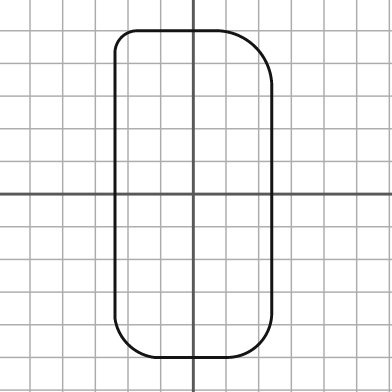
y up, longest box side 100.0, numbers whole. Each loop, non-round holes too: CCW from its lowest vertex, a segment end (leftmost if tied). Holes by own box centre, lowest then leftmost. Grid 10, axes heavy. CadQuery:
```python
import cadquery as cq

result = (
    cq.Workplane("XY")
    .moveTo(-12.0, -50.0)
    .lineTo(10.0, -50.0)
    .threePointArc((20.0, -46.0), (24.0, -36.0))
    .lineTo(24.0, 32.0)
    .threePointArc((19.0, 45.0), (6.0, 50.0))
    .lineTo(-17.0, 50.0)
    .threePointArc((-22.0, 48.0), (-24.0, 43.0))
    .lineTo(-24.0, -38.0)
    .threePointArc((-20.0, -46.0), (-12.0, -50.0))
    .close()
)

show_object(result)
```